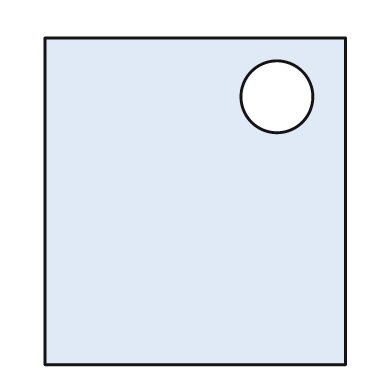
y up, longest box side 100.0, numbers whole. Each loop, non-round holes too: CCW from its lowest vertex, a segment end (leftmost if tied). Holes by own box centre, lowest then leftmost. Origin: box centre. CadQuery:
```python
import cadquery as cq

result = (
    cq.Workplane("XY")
    .moveTo(-46.0, -50.0)
    .lineTo(46.0, -50.0)
    .lineTo(46.0, 50.0)
    .lineTo(-46.0, 50.0)
    .close()
    .moveTo(25.0, 32.0)
    .circle(11.0)
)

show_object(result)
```